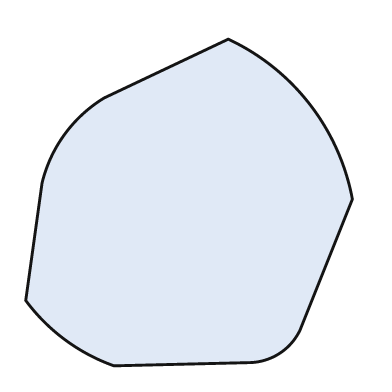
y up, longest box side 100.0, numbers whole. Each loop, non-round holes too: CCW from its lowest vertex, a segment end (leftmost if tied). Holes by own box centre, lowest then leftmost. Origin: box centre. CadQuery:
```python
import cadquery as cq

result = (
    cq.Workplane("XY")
    .moveTo(-23.0, -50.0)
    .lineTo(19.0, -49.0)
    .threePointArc((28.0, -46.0), (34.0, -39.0))
    .lineTo(50.0, 1.0)
    .threePointArc((37.0, 30.0), (12.0, 50.0))
    .lineTo(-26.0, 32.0)
    .threePointArc((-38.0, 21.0), (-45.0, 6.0))
    .lineTo(-50.0, -30.0)
    .threePointArc((-38.0, -42.0), (-23.0, -50.0))
    .close()
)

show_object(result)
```